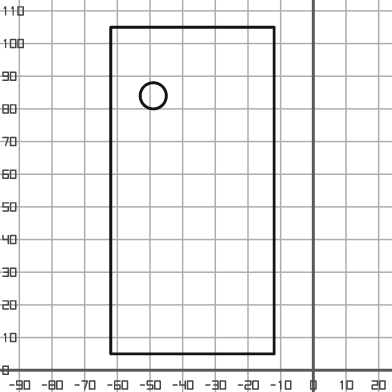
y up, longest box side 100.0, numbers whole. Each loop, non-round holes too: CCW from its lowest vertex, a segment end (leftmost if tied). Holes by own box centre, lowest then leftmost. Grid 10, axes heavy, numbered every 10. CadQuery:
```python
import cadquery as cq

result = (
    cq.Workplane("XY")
    .moveTo(-62.0, 5.0)
    .lineTo(-12.0, 5.0)
    .lineTo(-12.0, 105.0)
    .lineTo(-62.0, 105.0)
    .close()
    .moveTo(-49.0, 84.0)
    .circle(4.0)
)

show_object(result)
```